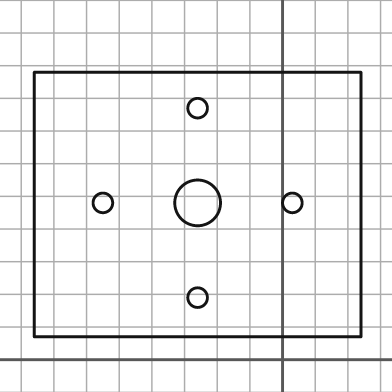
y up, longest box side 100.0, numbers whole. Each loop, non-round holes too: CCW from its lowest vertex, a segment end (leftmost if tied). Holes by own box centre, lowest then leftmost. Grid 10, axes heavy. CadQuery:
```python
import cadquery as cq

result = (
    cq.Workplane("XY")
    .moveTo(-76.0, 7.0)
    .lineTo(24.0, 7.0)
    .lineTo(24.0, 88.0)
    .lineTo(-76.0, 88.0)
    .close()
    .moveTo(-26.0, 19.0)
    .circle(3.0)
    .moveTo(-55.0, 48.0)
    .circle(3.0)
    .moveTo(-26.0, 48.0)
    .circle(7.0)
    .moveTo(3.0, 48.0)
    .circle(3.0)
    .moveTo(-26.0, 77.0)
    .circle(3.0)
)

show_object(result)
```